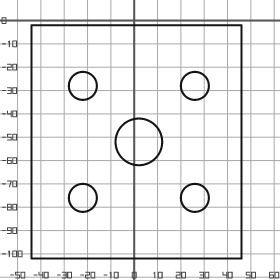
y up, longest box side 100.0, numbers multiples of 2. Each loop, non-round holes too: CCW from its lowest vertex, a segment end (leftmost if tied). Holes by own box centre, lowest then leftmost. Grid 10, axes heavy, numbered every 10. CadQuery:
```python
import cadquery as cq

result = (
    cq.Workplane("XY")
    .moveTo(-44.0, -102.0)
    .lineTo(46.0, -102.0)
    .lineTo(46.0, -2.0)
    .lineTo(-44.0, -2.0)
    .close()
    .moveTo(-22.0, -76.0)
    .circle(6.0)
    .moveTo(26.0, -76.0)
    .circle(6.0)
    .moveTo(2.0, -52.0)
    .circle(10.0)
    .moveTo(-22.0, -28.0)
    .circle(6.0)
    .moveTo(26.0, -28.0)
    .circle(6.0)
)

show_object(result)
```